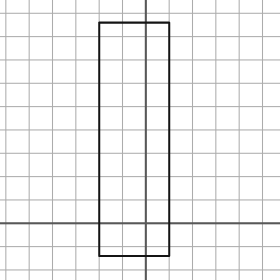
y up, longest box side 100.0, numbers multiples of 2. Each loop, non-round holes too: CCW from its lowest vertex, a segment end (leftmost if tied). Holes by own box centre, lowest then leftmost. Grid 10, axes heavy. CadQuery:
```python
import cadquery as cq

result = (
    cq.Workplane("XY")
    .moveTo(-20.0, -14.0)
    .lineTo(10.0, -14.0)
    .lineTo(10.0, 86.0)
    .lineTo(-20.0, 86.0)
    .close()
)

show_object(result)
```